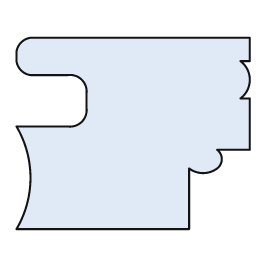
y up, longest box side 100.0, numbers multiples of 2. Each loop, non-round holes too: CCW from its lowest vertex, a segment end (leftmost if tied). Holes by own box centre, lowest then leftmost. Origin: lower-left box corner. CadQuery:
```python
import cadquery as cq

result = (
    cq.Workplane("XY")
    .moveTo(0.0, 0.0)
    .lineTo(74.0, 0.0)
    .lineTo(74.0, 26.0)
    .threePointArc((80.0, 24.0), (86.0, 26.0))
    .threePointArc((88.0, 30.0), (86.0, 34.0))
    .lineTo(100.0, 34.0)
    .lineTo(100.0, 56.0)
    .lineTo(96.0, 56.0)
    .threePointArc((100.0, 64.0), (96.0, 72.0))
    .lineTo(100.0, 72.0)
    .lineTo(100.0, 82.0)
    .lineTo(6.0, 82.0)
    .threePointArc((2.0, 80.0), (0.0, 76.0))
    .lineTo(0.0, 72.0)
    .threePointArc((2.0, 68.0), (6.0, 66.0))
    .lineTo(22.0, 66.0)
    .threePointArc((28.0, 64.0), (30.0, 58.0))
    .lineTo(30.0, 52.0)
    .threePointArc((28.0, 46.0), (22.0, 44.0))
    .lineTo(0.0, 44.0)
    .threePointArc((6.0, 22.0), (0.0, 0.0))
    .close()
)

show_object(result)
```